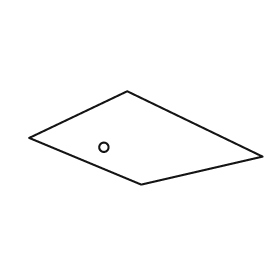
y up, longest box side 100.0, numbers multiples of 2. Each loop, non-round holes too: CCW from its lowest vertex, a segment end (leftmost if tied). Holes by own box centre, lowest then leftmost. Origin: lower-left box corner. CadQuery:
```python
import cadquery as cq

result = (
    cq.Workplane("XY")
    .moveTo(48.0, 0.0)
    .lineTo(100.0, 12.0)
    .lineTo(42.0, 40.0)
    .lineTo(0.0, 20.0)
    .close()
    .moveTo(32.0, 16.0)
    .circle(2.0)
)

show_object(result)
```